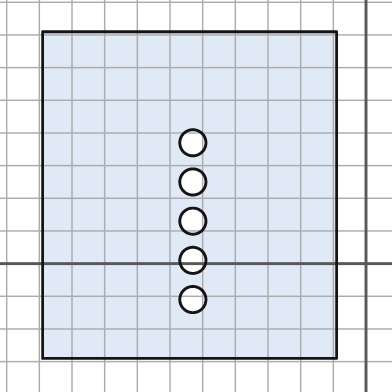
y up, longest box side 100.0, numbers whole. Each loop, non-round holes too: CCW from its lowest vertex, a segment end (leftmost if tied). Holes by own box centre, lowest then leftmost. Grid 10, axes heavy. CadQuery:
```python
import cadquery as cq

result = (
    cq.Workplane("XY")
    .moveTo(-99.0, -29.0)
    .lineTo(-9.0, -29.0)
    .lineTo(-9.0, 71.0)
    .lineTo(-99.0, 71.0)
    .close()
    .moveTo(-53.0, -11.0)
    .circle(4.0)
    .moveTo(-53.0, 1.0)
    .circle(4.0)
    .moveTo(-53.0, 13.0)
    .circle(4.0)
    .moveTo(-53.0, 25.0)
    .circle(4.0)
    .moveTo(-53.0, 37.0)
    .circle(4.0)
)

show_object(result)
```